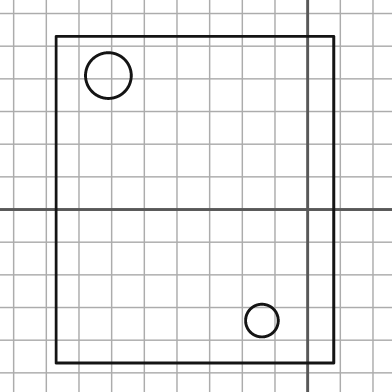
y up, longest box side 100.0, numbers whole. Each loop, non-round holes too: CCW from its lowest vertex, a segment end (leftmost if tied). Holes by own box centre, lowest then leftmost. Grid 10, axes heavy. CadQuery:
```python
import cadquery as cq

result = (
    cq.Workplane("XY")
    .moveTo(-77.0, -47.0)
    .lineTo(8.0, -47.0)
    .lineTo(8.0, 53.0)
    .lineTo(-77.0, 53.0)
    .close()
    .moveTo(-14.0, -34.0)
    .circle(5.0)
    .moveTo(-61.0, 41.0)
    .circle(7.0)
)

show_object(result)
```